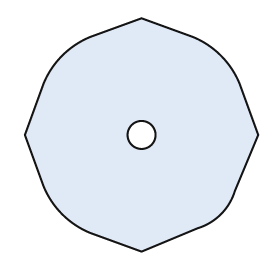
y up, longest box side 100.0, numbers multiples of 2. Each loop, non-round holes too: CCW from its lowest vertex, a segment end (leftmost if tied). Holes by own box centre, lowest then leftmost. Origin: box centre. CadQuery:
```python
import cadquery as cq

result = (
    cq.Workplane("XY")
    .moveTo(0.0, -50.0)
    .lineTo(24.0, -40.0)
    .threePointArc((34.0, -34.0), (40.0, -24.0))
    .lineTo(50.0, 0.0)
    .lineTo(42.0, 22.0)
    .threePointArc((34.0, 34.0), (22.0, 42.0))
    .lineTo(0.0, 50.0)
    .lineTo(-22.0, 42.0)
    .threePointArc((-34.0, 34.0), (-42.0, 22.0))
    .lineTo(-50.0, 0.0)
    .lineTo(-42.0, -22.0)
    .threePointArc((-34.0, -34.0), (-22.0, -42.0))
    .close()
    .moveTo(0.0, 0.0)
    .circle(6.0)
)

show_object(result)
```